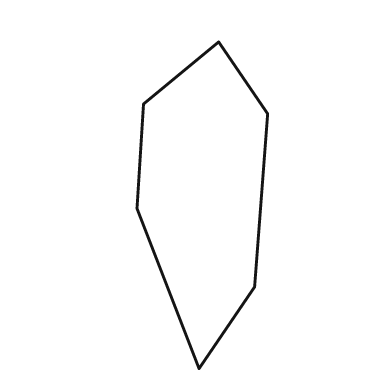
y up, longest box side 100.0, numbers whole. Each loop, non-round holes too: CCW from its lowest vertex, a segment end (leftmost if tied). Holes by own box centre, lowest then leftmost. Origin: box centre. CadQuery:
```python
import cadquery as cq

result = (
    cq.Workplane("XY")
    .moveTo(-1.0, -50.0)
    .lineTo(16.0, -25.0)
    .lineTo(20.0, 28.0)
    .lineTo(5.0, 50.0)
    .lineTo(-18.0, 31.0)
    .lineTo(-20.0, -1.0)
    .close()
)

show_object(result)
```